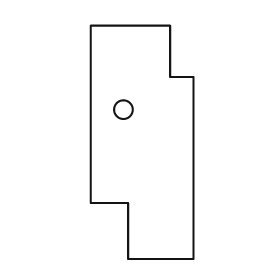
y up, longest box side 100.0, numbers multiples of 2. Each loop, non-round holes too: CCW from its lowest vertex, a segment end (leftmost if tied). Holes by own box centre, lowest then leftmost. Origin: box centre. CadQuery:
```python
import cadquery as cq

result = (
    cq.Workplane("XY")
    .moveTo(-6.0, -50.0)
    .lineTo(22.0, -50.0)
    .lineTo(22.0, 28.0)
    .lineTo(12.0, 28.0)
    .lineTo(12.0, 50.0)
    .lineTo(-22.0, 50.0)
    .lineTo(-22.0, -26.0)
    .lineTo(-6.0, -26.0)
    .close()
    .moveTo(-8.0, 14.0)
    .circle(4.0)
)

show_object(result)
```